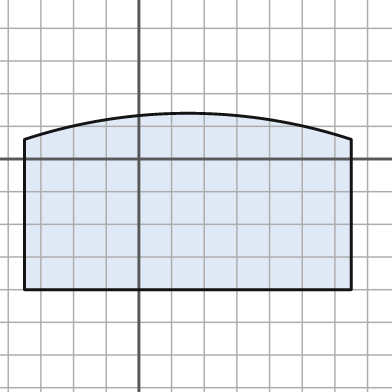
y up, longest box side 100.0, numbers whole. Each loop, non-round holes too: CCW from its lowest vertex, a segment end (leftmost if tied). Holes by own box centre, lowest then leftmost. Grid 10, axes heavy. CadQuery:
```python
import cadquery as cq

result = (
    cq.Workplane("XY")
    .moveTo(-35.0, -40.0)
    .lineTo(65.0, -40.0)
    .lineTo(65.0, 6.0)
    .threePointArc((15.0, 14.0), (-35.0, 6.0))
    .close()
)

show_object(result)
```